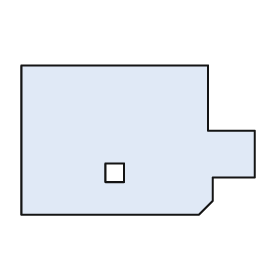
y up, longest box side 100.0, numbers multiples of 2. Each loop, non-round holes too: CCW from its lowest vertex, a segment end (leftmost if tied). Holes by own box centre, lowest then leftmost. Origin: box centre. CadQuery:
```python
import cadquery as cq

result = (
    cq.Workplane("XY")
    .moveTo(-50.0, -32.0)
    .lineTo(26.0, -32.0)
    .lineTo(32.0, -26.0)
    .lineTo(32.0, -16.0)
    .lineTo(50.0, -16.0)
    .lineTo(50.0, 4.0)
    .lineTo(30.0, 4.0)
    .lineTo(30.0, 32.0)
    .lineTo(-50.0, 32.0)
    .close()
    .moveTo(-14.0, -18.0)
    .lineTo(-6.0, -18.0)
    .lineTo(-6.0, -10.0)
    .lineTo(-14.0, -10.0)
    .close()
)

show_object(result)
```